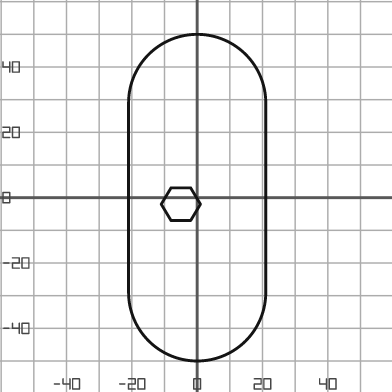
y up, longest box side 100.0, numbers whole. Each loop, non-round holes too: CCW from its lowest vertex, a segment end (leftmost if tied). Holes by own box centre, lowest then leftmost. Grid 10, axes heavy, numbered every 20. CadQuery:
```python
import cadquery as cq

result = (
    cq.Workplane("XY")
    .moveTo(-21.0, -29.0)
    .threePointArc((0.0, -50.0), (21.0, -29.0))
    .lineTo(21.0, 29.0)
    .threePointArc((0.0, 50.0), (-21.0, 29.0))
    .close()
    .moveTo(-8.0, -7.0)
    .lineTo(-2.0, -7.0)
    .lineTo(1.0, -2.0)
    .lineTo(-2.0, 3.0)
    .lineTo(-8.0, 3.0)
    .lineTo(-11.0, -2.0)
    .close()
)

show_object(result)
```